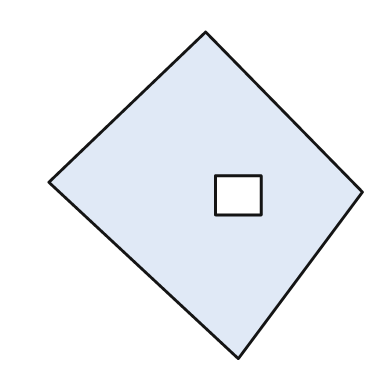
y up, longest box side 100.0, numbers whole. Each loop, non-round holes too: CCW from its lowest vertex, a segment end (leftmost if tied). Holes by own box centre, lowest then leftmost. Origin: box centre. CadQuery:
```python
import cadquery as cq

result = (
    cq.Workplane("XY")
    .moveTo(10.0, -50.0)
    .lineTo(48.0, 1.0)
    .lineTo(0.0, 50.0)
    .lineTo(-48.0, 4.0)
    .close()
    .moveTo(3.0, -6.0)
    .lineTo(17.0, -6.0)
    .lineTo(17.0, 6.0)
    .lineTo(3.0, 6.0)
    .close()
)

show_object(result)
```